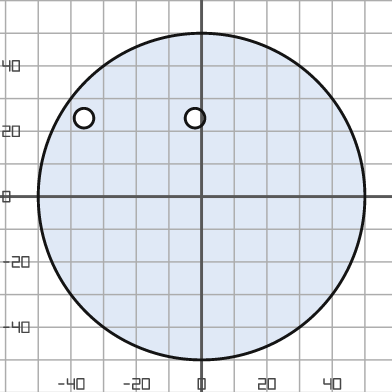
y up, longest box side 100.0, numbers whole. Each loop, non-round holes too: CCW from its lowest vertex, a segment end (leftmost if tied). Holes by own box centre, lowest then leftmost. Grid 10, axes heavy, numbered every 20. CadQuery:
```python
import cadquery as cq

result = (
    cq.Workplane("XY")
    .moveTo(0.0, 0.0)
    .circle(50.0)
    .moveTo(-36.0, 24.0)
    .circle(3.0)
    .moveTo(-2.0, 24.0)
    .circle(3.0)
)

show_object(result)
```